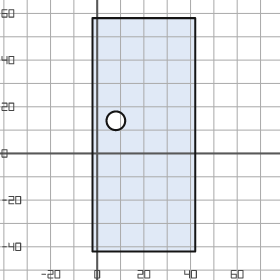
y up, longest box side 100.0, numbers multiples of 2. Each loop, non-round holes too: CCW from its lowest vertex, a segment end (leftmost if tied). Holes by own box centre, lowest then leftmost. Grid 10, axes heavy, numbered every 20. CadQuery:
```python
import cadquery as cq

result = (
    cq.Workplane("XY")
    .moveTo(-2.0, -42.0)
    .lineTo(42.0, -42.0)
    .lineTo(42.0, 58.0)
    .lineTo(-2.0, 58.0)
    .close()
    .moveTo(8.0, 14.0)
    .circle(4.0)
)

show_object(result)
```